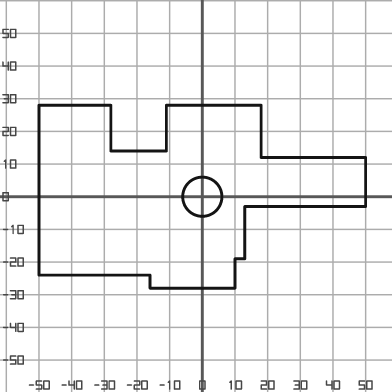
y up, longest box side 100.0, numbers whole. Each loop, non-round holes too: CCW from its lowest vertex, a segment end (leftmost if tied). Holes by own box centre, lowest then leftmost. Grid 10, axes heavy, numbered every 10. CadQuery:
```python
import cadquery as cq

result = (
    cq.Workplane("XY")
    .moveTo(-16.0, -28.0)
    .lineTo(10.0, -28.0)
    .lineTo(10.0, -19.0)
    .lineTo(13.0, -19.0)
    .lineTo(13.0, -3.0)
    .lineTo(50.0, -3.0)
    .lineTo(50.0, 12.0)
    .lineTo(18.0, 12.0)
    .lineTo(18.0, 28.0)
    .lineTo(-11.0, 28.0)
    .lineTo(-11.0, 14.0)
    .lineTo(-28.0, 14.0)
    .lineTo(-28.0, 28.0)
    .lineTo(-50.0, 28.0)
    .lineTo(-50.0, -24.0)
    .lineTo(-16.0, -24.0)
    .close()
    .moveTo(0.0, 0.0)
    .circle(6.0)
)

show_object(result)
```